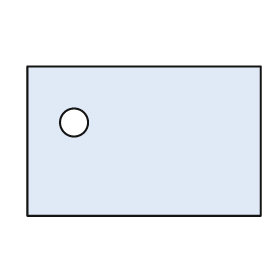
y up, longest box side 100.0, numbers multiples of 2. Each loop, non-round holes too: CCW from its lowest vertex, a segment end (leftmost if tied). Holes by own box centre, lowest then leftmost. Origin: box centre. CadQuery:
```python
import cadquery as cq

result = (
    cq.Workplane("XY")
    .moveTo(-50.0, -32.0)
    .lineTo(50.0, -32.0)
    .lineTo(50.0, 32.0)
    .lineTo(-50.0, 32.0)
    .close()
    .moveTo(-30.0, 8.0)
    .circle(6.0)
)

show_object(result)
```